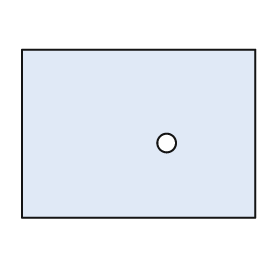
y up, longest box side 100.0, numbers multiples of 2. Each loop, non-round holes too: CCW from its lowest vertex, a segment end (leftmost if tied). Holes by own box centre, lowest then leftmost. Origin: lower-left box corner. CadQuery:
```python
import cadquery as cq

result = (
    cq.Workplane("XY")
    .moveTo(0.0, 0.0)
    .lineTo(100.0, 0.0)
    .lineTo(100.0, 72.0)
    .lineTo(0.0, 72.0)
    .close()
    .moveTo(62.0, 32.0)
    .circle(4.0)
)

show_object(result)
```